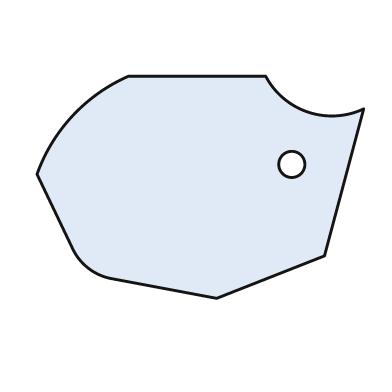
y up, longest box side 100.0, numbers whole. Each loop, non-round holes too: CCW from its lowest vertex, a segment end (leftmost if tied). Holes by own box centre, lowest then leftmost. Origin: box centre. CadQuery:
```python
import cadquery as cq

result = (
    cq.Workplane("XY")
    .moveTo(5.0, -34.0)
    .lineTo(38.0, -21.0)
    .lineTo(50.0, 24.0)
    .threePointArc((33.0, 23.0), (20.0, 34.0))
    .lineTo(-22.0, 34.0)
    .threePointArc((-39.0, 22.0), (-50.0, 4.0))
    .lineTo(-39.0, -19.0)
    .threePointArc((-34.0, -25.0), (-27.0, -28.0))
    .close()
    .moveTo(28.0, 7.0)
    .circle(4.0)
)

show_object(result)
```